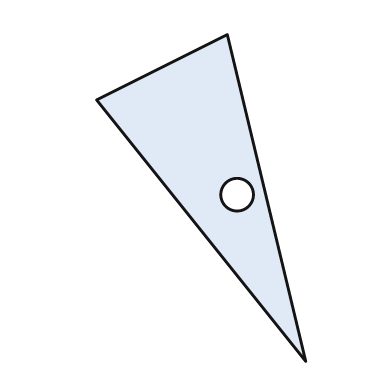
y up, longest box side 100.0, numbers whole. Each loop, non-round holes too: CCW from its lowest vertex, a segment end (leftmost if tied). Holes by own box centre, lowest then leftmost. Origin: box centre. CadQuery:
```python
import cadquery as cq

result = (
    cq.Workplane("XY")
    .moveTo(32.0, -50.0)
    .lineTo(8.0, 50.0)
    .lineTo(-32.0, 30.0)
    .close()
    .moveTo(11.0, 1.0)
    .circle(5.0)
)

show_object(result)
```